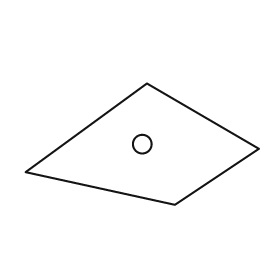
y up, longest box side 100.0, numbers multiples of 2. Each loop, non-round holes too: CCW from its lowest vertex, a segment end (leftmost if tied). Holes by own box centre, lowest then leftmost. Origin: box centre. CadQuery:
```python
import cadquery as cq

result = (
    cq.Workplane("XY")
    .moveTo(14.0, -26.0)
    .lineTo(50.0, -2.0)
    .lineTo(2.0, 26.0)
    .lineTo(-50.0, -12.0)
    .close()
    .moveTo(0.0, 0.0)
    .circle(4.0)
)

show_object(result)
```